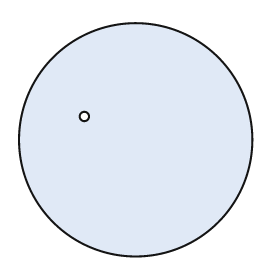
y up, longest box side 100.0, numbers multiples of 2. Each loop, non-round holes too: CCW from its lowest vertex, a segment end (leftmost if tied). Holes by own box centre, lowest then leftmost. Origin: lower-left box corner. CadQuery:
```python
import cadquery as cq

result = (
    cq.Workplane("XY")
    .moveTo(50.0, 50.0)
    .circle(50.0)
    .moveTo(28.0, 60.0)
    .circle(2.0)
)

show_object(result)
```